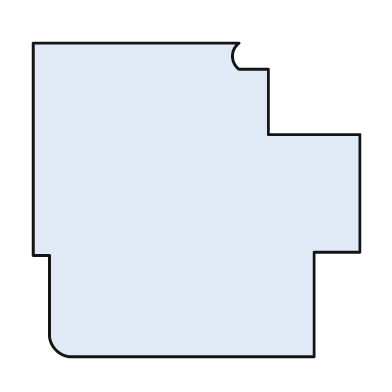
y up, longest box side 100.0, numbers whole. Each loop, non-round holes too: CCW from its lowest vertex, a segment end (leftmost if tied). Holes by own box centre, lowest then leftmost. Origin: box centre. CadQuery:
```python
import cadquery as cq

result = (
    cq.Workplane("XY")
    .moveTo(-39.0, -48.0)
    .lineTo(36.0, -48.0)
    .lineTo(36.0, -16.0)
    .lineTo(50.0, -16.0)
    .lineTo(50.0, 20.0)
    .lineTo(22.0, 20.0)
    .lineTo(22.0, 40.0)
    .lineTo(13.0, 40.0)
    .threePointArc((11.0, 44.0), (13.0, 48.0))
    .lineTo(-50.0, 48.0)
    .lineTo(-50.0, -17.0)
    .lineTo(-45.0, -17.0)
    .lineTo(-45.0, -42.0)
    .threePointArc((-43.0, -46.0), (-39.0, -48.0))
    .close()
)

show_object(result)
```